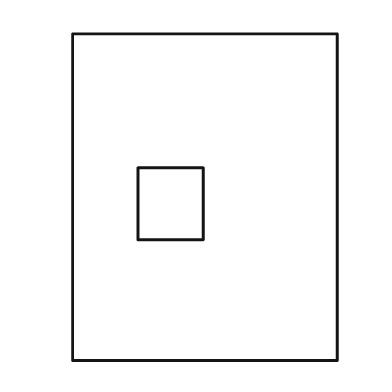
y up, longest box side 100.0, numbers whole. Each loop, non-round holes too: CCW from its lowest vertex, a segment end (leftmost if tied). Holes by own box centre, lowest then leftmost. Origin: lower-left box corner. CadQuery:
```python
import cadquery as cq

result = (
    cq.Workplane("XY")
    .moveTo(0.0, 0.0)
    .lineTo(81.0, 0.0)
    .lineTo(81.0, 100.0)
    .lineTo(0.0, 100.0)
    .close()
    .moveTo(20.0, 37.0)
    .lineTo(40.0, 37.0)
    .lineTo(40.0, 59.0)
    .lineTo(20.0, 59.0)
    .close()
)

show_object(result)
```